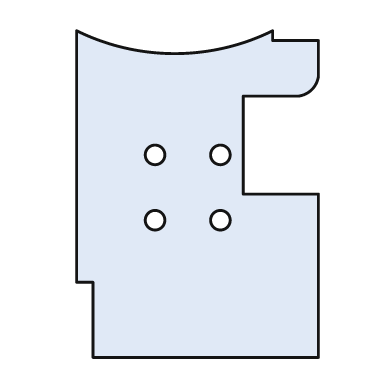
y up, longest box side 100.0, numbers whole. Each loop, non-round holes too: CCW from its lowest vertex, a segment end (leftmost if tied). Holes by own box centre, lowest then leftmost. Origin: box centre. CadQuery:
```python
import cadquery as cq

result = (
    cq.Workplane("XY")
    .moveTo(-32.0, -50.0)
    .lineTo(37.0, -50.0)
    .lineTo(37.0, 0.0)
    .lineTo(14.0, 0.0)
    .lineTo(14.0, 30.0)
    .lineTo(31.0, 30.0)
    .threePointArc((35.0, 32.0), (37.0, 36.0))
    .lineTo(37.0, 47.0)
    .lineTo(23.0, 47.0)
    .lineTo(23.0, 50.0)
    .threePointArc((-7.0, 43.0), (-37.0, 50.0))
    .lineTo(-37.0, -27.0)
    .lineTo(-32.0, -27.0)
    .close()
    .moveTo(-13.0, -8.0)
    .circle(3.0)
    .moveTo(7.0, -8.0)
    .circle(3.0)
    .moveTo(-13.0, 12.0)
    .circle(3.0)
    .moveTo(7.0, 12.0)
    .circle(3.0)
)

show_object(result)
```